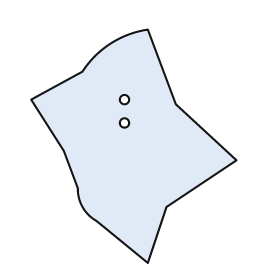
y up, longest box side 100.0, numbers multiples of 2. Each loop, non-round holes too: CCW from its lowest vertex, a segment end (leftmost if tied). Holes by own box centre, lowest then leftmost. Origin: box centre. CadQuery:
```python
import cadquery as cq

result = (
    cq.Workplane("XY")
    .moveTo(6.0, -50.0)
    .lineTo(14.0, -26.0)
    .lineTo(44.0, -6.0)
    .lineTo(18.0, 18.0)
    .lineTo(6.0, 50.0)
    .threePointArc((-10.0, 44.0), (-22.0, 32.0))
    .lineTo(-44.0, 20.0)
    .lineTo(-30.0, -2.0)
    .lineTo(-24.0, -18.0)
    .threePointArc((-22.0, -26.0), (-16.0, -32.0))
    .close()
    .moveTo(-4.0, 10.0)
    .circle(2.0)
    .moveTo(-4.0, 20.0)
    .circle(2.0)
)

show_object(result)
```